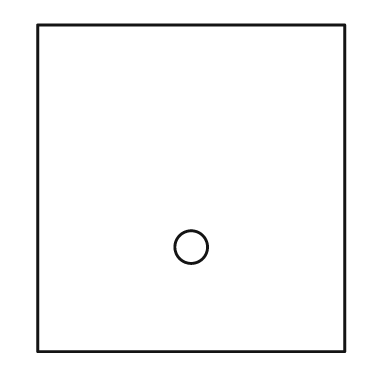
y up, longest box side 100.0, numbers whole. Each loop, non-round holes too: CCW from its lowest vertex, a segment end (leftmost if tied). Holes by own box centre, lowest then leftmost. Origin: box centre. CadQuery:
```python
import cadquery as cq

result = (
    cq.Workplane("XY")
    .moveTo(-47.0, -50.0)
    .lineTo(47.0, -50.0)
    .lineTo(47.0, 50.0)
    .lineTo(-47.0, 50.0)
    .close()
    .moveTo(0.0, -18.0)
    .circle(5.0)
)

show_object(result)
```